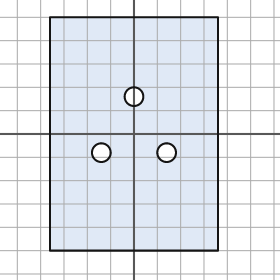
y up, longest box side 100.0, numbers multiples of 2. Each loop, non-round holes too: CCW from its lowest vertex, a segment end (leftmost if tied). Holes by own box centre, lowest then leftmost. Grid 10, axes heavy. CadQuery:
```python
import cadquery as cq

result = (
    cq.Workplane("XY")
    .moveTo(-36.0, -50.0)
    .lineTo(36.0, -50.0)
    .lineTo(36.0, 50.0)
    .lineTo(-36.0, 50.0)
    .close()
    .moveTo(-14.0, -8.0)
    .circle(4.0)
    .moveTo(14.0, -8.0)
    .circle(4.0)
    .moveTo(0.0, 16.0)
    .circle(4.0)
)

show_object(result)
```